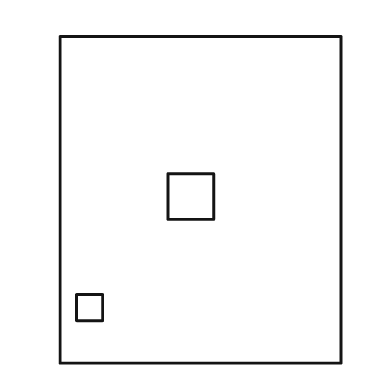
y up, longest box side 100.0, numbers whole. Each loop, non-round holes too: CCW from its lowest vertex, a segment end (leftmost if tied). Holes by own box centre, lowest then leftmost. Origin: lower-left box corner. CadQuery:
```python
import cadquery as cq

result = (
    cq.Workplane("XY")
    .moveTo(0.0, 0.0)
    .lineTo(86.0, 0.0)
    .lineTo(86.0, 100.0)
    .lineTo(0.0, 100.0)
    .close()
    .moveTo(5.0, 13.0)
    .lineTo(13.0, 13.0)
    .lineTo(13.0, 21.0)
    .lineTo(5.0, 21.0)
    .close()
    .moveTo(33.0, 44.0)
    .lineTo(47.0, 44.0)
    .lineTo(47.0, 58.0)
    .lineTo(33.0, 58.0)
    .close()
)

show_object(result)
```